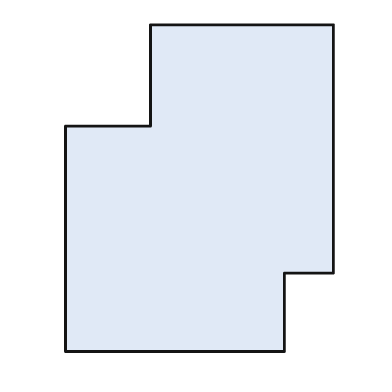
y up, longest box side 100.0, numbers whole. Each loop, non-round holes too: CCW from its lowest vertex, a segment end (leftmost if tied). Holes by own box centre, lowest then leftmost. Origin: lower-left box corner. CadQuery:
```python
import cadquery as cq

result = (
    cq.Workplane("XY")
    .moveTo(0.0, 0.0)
    .lineTo(67.0, 0.0)
    .lineTo(67.0, 24.0)
    .lineTo(82.0, 24.0)
    .lineTo(82.0, 100.0)
    .lineTo(26.0, 100.0)
    .lineTo(26.0, 69.0)
    .lineTo(0.0, 69.0)
    .close()
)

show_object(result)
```